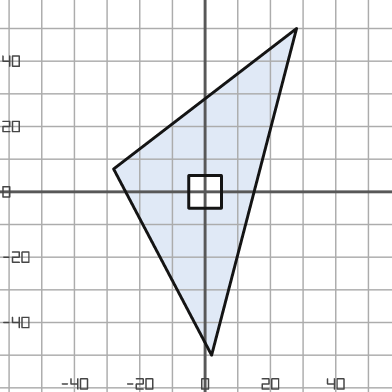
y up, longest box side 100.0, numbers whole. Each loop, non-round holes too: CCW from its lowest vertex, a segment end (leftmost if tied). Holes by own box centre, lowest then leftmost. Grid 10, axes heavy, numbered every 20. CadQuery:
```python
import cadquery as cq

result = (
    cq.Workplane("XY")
    .moveTo(2.0, -50.0)
    .lineTo(28.0, 50.0)
    .lineTo(-28.0, 7.0)
    .close()
    .moveTo(-5.0, -5.0)
    .lineTo(5.0, -5.0)
    .lineTo(5.0, 5.0)
    .lineTo(-5.0, 5.0)
    .close()
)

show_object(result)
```